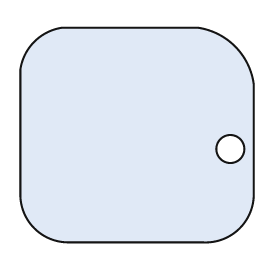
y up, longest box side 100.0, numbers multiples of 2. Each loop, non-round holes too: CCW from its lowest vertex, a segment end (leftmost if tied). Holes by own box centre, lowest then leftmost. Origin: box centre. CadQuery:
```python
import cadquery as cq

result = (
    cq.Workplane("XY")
    .moveTo(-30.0, -46.0)
    .lineTo(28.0, -46.0)
    .threePointArc((44.0, -40.0), (50.0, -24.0))
    .lineTo(50.0, 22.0)
    .threePointArc((42.0, 38.0), (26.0, 46.0))
    .lineTo(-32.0, 46.0)
    .threePointArc((-44.0, 40.0), (-50.0, 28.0))
    .lineTo(-50.0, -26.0)
    .threePointArc((-44.0, -40.0), (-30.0, -46.0))
    .close()
    .moveTo(40.0, -6.0)
    .circle(6.0)
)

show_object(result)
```